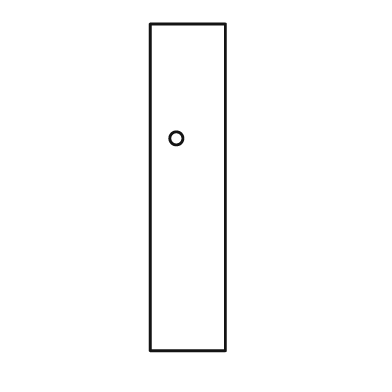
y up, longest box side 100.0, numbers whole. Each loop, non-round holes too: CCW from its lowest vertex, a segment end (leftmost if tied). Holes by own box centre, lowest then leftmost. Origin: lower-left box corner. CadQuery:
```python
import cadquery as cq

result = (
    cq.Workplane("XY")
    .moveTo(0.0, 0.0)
    .lineTo(23.0, 0.0)
    .lineTo(23.0, 100.0)
    .lineTo(0.0, 100.0)
    .close()
    .moveTo(8.0, 65.0)
    .circle(2.0)
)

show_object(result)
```